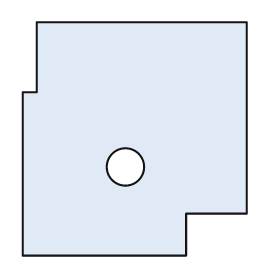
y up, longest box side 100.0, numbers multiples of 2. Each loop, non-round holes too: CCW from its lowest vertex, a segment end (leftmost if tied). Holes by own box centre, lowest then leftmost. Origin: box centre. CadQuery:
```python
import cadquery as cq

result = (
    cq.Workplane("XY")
    .moveTo(-48.0, -50.0)
    .lineTo(22.0, -50.0)
    .lineTo(22.0, -32.0)
    .lineTo(48.0, -32.0)
    .lineTo(48.0, 50.0)
    .lineTo(-42.0, 50.0)
    .lineTo(-42.0, 20.0)
    .lineTo(-48.0, 20.0)
    .close()
    .moveTo(-4.0, -12.0)
    .circle(8.0)
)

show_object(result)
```